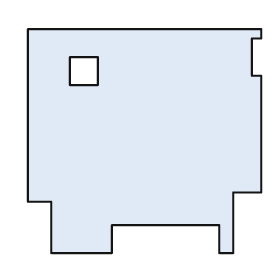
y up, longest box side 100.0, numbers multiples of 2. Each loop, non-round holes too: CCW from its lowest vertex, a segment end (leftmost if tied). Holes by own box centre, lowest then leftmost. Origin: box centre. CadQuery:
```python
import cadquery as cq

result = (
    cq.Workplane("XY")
    .moveTo(-40.0, -48.0)
    .lineTo(-14.0, -48.0)
    .lineTo(-14.0, -36.0)
    .lineTo(32.0, -36.0)
    .lineTo(32.0, -48.0)
    .lineTo(38.0, -48.0)
    .lineTo(38.0, -22.0)
    .lineTo(50.0, -22.0)
    .lineTo(50.0, 28.0)
    .lineTo(46.0, 28.0)
    .lineTo(46.0, 44.0)
    .lineTo(50.0, 44.0)
    .lineTo(50.0, 48.0)
    .lineTo(-50.0, 48.0)
    .lineTo(-50.0, -26.0)
    .lineTo(-40.0, -26.0)
    .close()
    .moveTo(-32.0, 24.0)
    .lineTo(-20.0, 24.0)
    .lineTo(-20.0, 36.0)
    .lineTo(-32.0, 36.0)
    .close()
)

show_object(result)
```